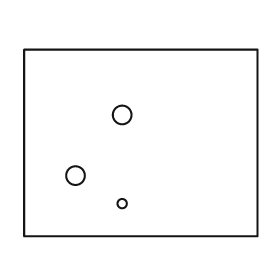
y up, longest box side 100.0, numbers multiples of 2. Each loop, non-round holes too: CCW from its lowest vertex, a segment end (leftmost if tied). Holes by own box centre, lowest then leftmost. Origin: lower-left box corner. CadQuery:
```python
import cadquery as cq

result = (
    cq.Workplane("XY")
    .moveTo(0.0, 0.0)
    .lineTo(100.0, 0.0)
    .lineTo(100.0, 80.0)
    .lineTo(0.0, 80.0)
    .close()
    .moveTo(42.0, 14.0)
    .circle(2.0)
    .moveTo(22.0, 26.0)
    .circle(4.0)
    .moveTo(42.0, 52.0)
    .circle(4.0)
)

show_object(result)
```